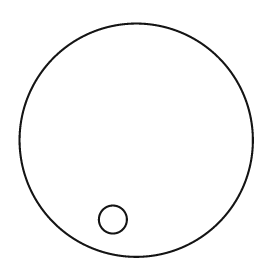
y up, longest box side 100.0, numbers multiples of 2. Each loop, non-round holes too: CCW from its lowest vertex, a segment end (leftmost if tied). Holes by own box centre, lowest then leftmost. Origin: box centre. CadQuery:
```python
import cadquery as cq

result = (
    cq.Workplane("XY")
    .moveTo(0.0, 0.0)
    .circle(50.0)
    .moveTo(-10.0, -34.0)
    .circle(6.0)
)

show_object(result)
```